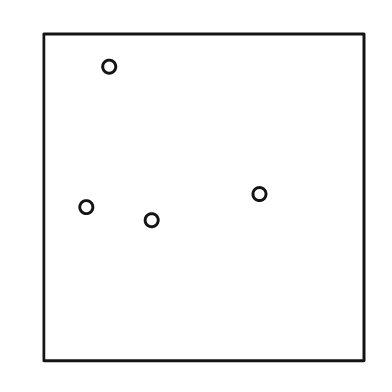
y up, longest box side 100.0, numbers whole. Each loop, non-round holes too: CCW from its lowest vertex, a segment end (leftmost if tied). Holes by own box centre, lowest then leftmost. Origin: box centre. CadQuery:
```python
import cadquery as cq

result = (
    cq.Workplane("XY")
    .moveTo(-49.0, -50.0)
    .lineTo(49.0, -50.0)
    .lineTo(49.0, 50.0)
    .lineTo(-49.0, 50.0)
    .close()
    .moveTo(-16.0, -7.0)
    .circle(2.0)
    .moveTo(-36.0, -3.0)
    .circle(2.0)
    .moveTo(17.0, 1.0)
    .circle(2.0)
    .moveTo(-29.0, 40.0)
    .circle(2.0)
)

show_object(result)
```